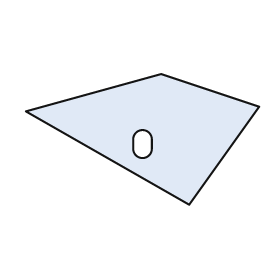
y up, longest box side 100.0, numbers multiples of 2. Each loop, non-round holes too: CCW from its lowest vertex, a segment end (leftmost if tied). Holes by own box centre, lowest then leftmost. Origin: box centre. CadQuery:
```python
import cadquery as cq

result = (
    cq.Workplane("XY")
    .moveTo(20.0, -28.0)
    .lineTo(50.0, 14.0)
    .lineTo(8.0, 28.0)
    .lineTo(-50.0, 12.0)
    .close()
    .moveTo(-4.0, -4.0)
    .threePointArc((0.0, -8.0), (4.0, -4.0))
    .lineTo(4.0, 0.0)
    .threePointArc((0.0, 4.0), (-4.0, 0.0))
    .close()
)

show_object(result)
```